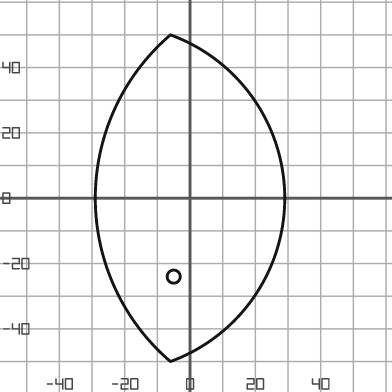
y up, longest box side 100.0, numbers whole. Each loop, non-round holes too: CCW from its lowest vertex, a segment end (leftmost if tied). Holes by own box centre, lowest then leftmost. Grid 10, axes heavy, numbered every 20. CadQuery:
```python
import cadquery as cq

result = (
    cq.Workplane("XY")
    .moveTo(-6.0, -50.0)
    .threePointArc((29.0, 0.0), (-6.0, 50.0))
    .threePointArc((-29.0, 0.0), (-6.0, -50.0))
    .close()
    .moveTo(-5.0, -24.0)
    .circle(2.0)
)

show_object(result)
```